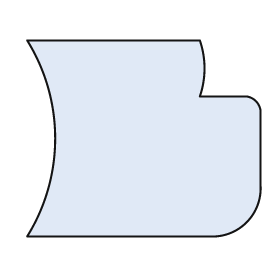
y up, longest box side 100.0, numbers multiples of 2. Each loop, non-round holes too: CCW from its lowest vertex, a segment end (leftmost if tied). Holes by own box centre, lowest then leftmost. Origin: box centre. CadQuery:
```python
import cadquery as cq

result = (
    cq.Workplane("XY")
    .moveTo(-50.0, -42.0)
    .lineTo(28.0, -42.0)
    .threePointArc((44.0, -36.0), (50.0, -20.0))
    .lineTo(50.0, 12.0)
    .threePointArc((48.0, 16.0), (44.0, 18.0))
    .lineTo(24.0, 18.0)
    .threePointArc((26.0, 30.0), (24.0, 42.0))
    .lineTo(-50.0, 42.0)
    .threePointArc((-38.0, 0.0), (-50.0, -42.0))
    .close()
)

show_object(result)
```